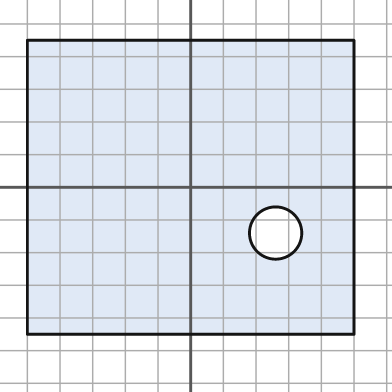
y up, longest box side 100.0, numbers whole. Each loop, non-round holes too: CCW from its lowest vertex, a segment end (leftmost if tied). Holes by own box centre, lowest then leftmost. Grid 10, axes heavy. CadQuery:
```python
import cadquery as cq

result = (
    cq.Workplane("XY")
    .moveTo(-50.0, -45.0)
    .lineTo(50.0, -45.0)
    .lineTo(50.0, 45.0)
    .lineTo(-50.0, 45.0)
    .close()
    .moveTo(26.0, -14.0)
    .circle(8.0)
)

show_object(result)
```